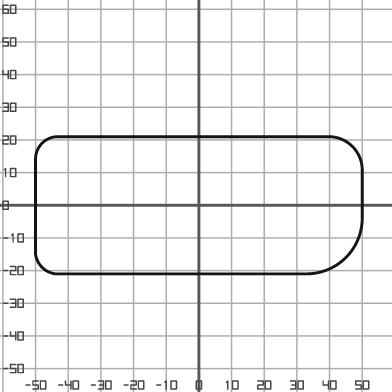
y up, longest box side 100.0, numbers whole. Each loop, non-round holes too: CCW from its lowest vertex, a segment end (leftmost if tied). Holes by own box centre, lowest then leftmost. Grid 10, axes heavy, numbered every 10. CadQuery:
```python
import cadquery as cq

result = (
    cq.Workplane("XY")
    .moveTo(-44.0, -21.0)
    .lineTo(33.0, -21.0)
    .threePointArc((45.0, -16.0), (50.0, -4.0))
    .lineTo(50.0, 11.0)
    .threePointArc((47.0, 18.0), (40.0, 21.0))
    .lineTo(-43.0, 21.0)
    .threePointArc((-48.0, 19.0), (-50.0, 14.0))
    .lineTo(-50.0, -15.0)
    .threePointArc((-48.0, -19.0), (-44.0, -21.0))
    .close()
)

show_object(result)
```